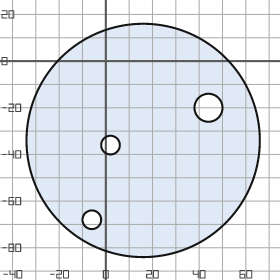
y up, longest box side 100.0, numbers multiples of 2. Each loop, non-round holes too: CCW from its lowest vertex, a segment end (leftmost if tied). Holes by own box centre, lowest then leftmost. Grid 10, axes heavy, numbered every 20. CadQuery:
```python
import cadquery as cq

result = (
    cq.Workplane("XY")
    .moveTo(16.0, -34.0)
    .circle(50.0)
    .moveTo(-6.0, -68.0)
    .circle(4.0)
    .moveTo(2.0, -36.0)
    .circle(4.0)
    .moveTo(44.0, -20.0)
    .circle(6.0)
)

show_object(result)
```